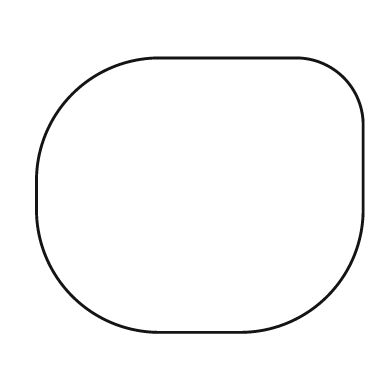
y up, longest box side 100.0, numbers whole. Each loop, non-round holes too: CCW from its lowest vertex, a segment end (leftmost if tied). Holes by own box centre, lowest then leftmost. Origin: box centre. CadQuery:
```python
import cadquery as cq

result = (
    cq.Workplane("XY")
    .moveTo(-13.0, -42.0)
    .lineTo(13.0, -42.0)
    .threePointArc((39.0, -31.0), (50.0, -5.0))
    .lineTo(50.0, 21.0)
    .threePointArc((44.0, 36.0), (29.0, 42.0))
    .lineTo(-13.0, 42.0)
    .threePointArc((-39.0, 31.0), (-50.0, 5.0))
    .lineTo(-50.0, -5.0)
    .threePointArc((-39.0, -31.0), (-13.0, -42.0))
    .close()
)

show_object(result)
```